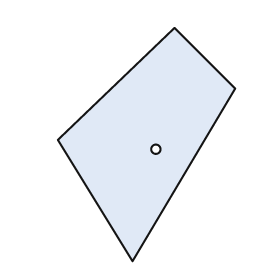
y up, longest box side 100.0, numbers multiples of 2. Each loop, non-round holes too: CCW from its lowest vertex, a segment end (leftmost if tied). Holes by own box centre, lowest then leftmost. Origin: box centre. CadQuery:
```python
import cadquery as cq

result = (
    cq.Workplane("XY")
    .moveTo(-6.0, -50.0)
    .lineTo(38.0, 24.0)
    .lineTo(12.0, 50.0)
    .lineTo(-38.0, 2.0)
    .close()
    .moveTo(4.0, -2.0)
    .circle(2.0)
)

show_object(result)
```